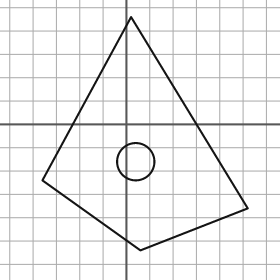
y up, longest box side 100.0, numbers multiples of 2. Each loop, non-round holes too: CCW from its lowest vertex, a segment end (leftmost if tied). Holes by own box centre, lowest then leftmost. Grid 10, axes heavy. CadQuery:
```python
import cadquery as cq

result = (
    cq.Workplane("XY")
    .moveTo(6.0, -54.0)
    .lineTo(52.0, -36.0)
    .lineTo(2.0, 46.0)
    .lineTo(-36.0, -24.0)
    .close()
    .moveTo(4.0, -16.0)
    .circle(8.0)
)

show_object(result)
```